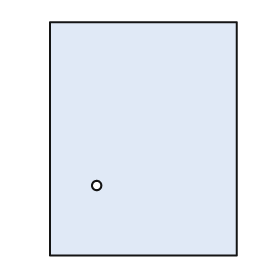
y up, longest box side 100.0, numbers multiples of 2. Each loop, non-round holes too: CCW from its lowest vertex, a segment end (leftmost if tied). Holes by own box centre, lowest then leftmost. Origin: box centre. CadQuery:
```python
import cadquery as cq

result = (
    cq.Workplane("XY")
    .moveTo(-40.0, -50.0)
    .lineTo(40.0, -50.0)
    .lineTo(40.0, 50.0)
    .lineTo(-40.0, 50.0)
    .close()
    .moveTo(-20.0, -20.0)
    .circle(2.0)
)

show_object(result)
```